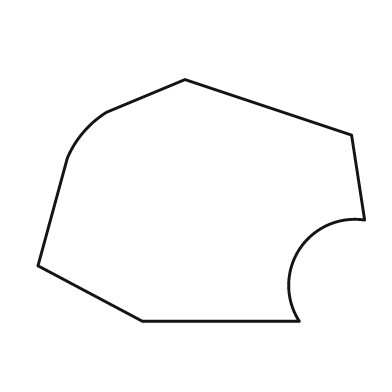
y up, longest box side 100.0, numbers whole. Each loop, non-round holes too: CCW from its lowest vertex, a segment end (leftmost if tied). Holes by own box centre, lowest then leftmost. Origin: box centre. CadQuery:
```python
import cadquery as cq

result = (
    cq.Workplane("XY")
    .moveTo(-18.0, -37.0)
    .lineTo(30.0, -37.0)
    .threePointArc((30.0, -15.0), (50.0, -6.0))
    .lineTo(46.0, 20.0)
    .lineTo(-5.0, 37.0)
    .lineTo(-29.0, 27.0)
    .threePointArc((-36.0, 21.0), (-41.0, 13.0))
    .lineTo(-50.0, -20.0)
    .close()
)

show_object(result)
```